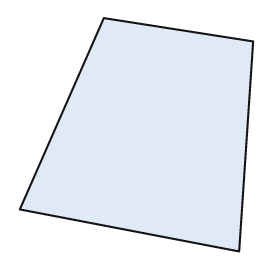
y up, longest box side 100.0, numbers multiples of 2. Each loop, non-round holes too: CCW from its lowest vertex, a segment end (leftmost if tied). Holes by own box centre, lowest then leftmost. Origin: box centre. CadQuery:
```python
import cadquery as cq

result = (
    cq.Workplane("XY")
    .moveTo(44.0, -50.0)
    .lineTo(50.0, 40.0)
    .lineTo(-14.0, 50.0)
    .lineTo(-50.0, -32.0)
    .close()
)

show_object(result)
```